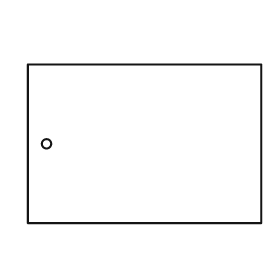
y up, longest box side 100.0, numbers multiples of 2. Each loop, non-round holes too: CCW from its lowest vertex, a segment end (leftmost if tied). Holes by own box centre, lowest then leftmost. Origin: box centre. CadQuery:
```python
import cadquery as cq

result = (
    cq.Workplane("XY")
    .moveTo(-50.0, -34.0)
    .lineTo(50.0, -34.0)
    .lineTo(50.0, 34.0)
    .lineTo(-50.0, 34.0)
    .close()
    .moveTo(-42.0, 0.0)
    .circle(2.0)
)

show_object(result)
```